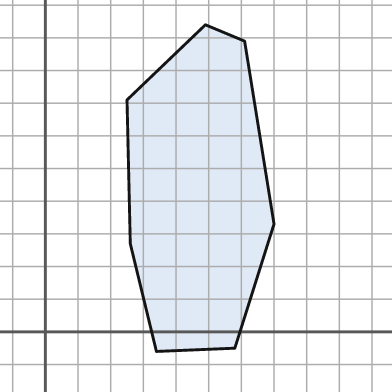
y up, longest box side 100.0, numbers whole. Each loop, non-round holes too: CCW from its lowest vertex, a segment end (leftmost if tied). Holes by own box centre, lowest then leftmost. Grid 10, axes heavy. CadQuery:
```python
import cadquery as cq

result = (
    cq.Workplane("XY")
    .moveTo(34.0, -6.0)
    .lineTo(58.0, -5.0)
    .lineTo(70.0, 33.0)
    .lineTo(61.0, 89.0)
    .lineTo(49.0, 94.0)
    .lineTo(25.0, 71.0)
    .lineTo(26.0, 27.0)
    .close()
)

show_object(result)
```